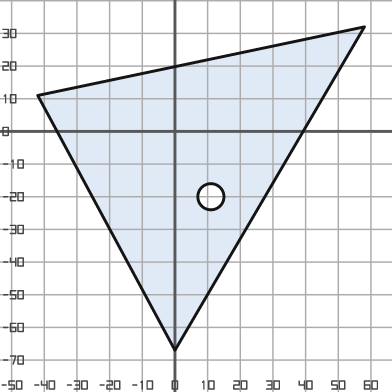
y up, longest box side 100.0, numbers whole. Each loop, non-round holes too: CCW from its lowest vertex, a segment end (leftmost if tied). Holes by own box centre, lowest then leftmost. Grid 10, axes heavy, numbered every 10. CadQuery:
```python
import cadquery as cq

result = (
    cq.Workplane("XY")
    .moveTo(0.0, -67.0)
    .lineTo(58.0, 32.0)
    .lineTo(-42.0, 11.0)
    .close()
    .moveTo(11.0, -20.0)
    .circle(4.0)
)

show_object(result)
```